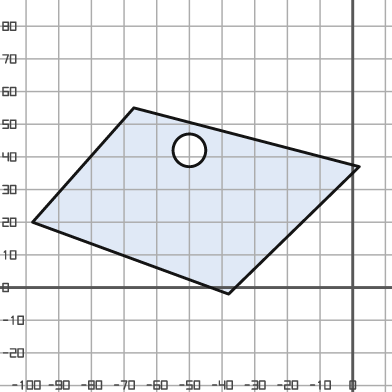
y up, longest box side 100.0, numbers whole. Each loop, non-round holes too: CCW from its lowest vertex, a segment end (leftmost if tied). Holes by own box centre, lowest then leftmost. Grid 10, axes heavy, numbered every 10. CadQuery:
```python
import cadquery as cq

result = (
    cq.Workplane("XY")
    .moveTo(-38.0, -2.0)
    .lineTo(2.0, 37.0)
    .lineTo(-67.0, 55.0)
    .lineTo(-98.0, 20.0)
    .close()
    .moveTo(-50.0, 42.0)
    .circle(5.0)
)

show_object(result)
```